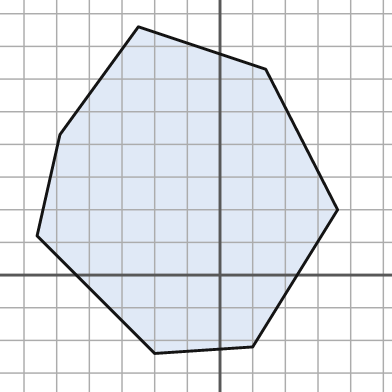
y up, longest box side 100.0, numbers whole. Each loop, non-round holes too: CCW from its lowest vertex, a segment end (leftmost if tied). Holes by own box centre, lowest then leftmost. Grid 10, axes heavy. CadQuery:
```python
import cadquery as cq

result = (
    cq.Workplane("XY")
    .moveTo(-20.0, -24.0)
    .lineTo(10.0, -22.0)
    .lineTo(36.0, 20.0)
    .lineTo(14.0, 63.0)
    .lineTo(-25.0, 76.0)
    .lineTo(-49.0, 43.0)
    .lineTo(-56.0, 12.0)
    .close()
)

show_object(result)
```